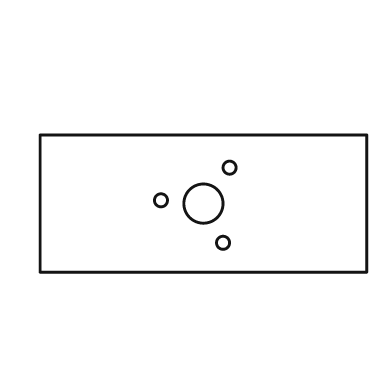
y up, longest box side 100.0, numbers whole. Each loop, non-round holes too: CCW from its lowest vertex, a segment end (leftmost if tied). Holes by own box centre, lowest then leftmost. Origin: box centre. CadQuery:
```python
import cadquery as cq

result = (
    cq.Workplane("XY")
    .moveTo(-50.0, -21.0)
    .lineTo(50.0, -21.0)
    .lineTo(50.0, 21.0)
    .lineTo(-50.0, 21.0)
    .close()
    .moveTo(6.0, -12.0)
    .circle(2.0)
    .moveTo(0.0, 0.0)
    .circle(6.0)
    .moveTo(-13.0, 1.0)
    .circle(2.0)
    .moveTo(8.0, 11.0)
    .circle(2.0)
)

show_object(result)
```